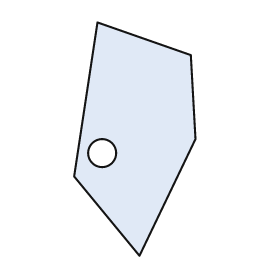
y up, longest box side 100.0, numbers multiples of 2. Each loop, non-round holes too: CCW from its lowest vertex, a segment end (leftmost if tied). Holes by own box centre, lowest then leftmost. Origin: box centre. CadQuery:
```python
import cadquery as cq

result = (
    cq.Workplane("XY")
    .moveTo(2.0, -50.0)
    .lineTo(26.0, 0.0)
    .lineTo(24.0, 36.0)
    .lineTo(-16.0, 50.0)
    .lineTo(-26.0, -16.0)
    .close()
    .moveTo(-14.0, -6.0)
    .circle(6.0)
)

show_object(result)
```